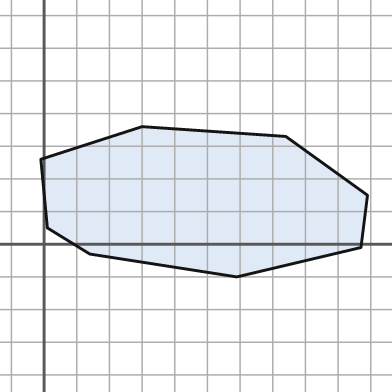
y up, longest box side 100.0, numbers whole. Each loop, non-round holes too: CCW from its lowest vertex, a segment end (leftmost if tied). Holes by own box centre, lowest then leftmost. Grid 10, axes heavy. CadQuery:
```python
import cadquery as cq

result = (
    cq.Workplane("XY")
    .moveTo(59.0, -10.0)
    .lineTo(97.0, -1.0)
    .lineTo(99.0, 15.0)
    .lineTo(74.0, 33.0)
    .lineTo(30.0, 36.0)
    .lineTo(-1.0, 26.0)
    .lineTo(1.0, 5.0)
    .lineTo(14.0, -3.0)
    .close()
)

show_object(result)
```